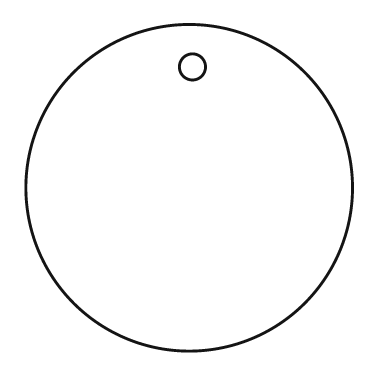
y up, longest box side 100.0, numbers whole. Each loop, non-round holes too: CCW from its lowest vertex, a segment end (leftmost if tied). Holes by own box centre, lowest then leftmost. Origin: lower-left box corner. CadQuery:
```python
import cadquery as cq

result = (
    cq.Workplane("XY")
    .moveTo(50.0, 50.0)
    .circle(50.0)
    .moveTo(51.0, 87.0)
    .circle(4.0)
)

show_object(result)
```